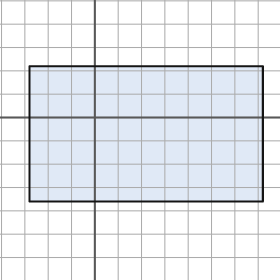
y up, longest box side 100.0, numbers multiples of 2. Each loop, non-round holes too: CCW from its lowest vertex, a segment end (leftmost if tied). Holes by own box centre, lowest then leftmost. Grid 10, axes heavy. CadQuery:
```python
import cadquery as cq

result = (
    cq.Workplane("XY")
    .moveTo(-28.0, -36.0)
    .lineTo(72.0, -36.0)
    .lineTo(72.0, 22.0)
    .lineTo(-28.0, 22.0)
    .close()
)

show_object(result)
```